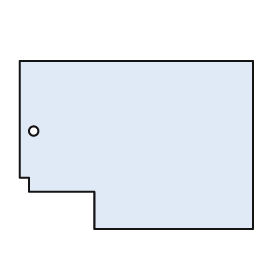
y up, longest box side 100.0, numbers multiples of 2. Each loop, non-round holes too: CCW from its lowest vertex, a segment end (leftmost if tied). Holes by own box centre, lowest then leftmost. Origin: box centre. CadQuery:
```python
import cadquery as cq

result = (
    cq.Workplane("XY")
    .moveTo(-18.0, -36.0)
    .lineTo(50.0, -36.0)
    .lineTo(50.0, 36.0)
    .lineTo(-50.0, 36.0)
    .lineTo(-50.0, -14.0)
    .lineTo(-46.0, -14.0)
    .lineTo(-46.0, -20.0)
    .lineTo(-18.0, -20.0)
    .close()
    .moveTo(-44.0, 6.0)
    .circle(2.0)
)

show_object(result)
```